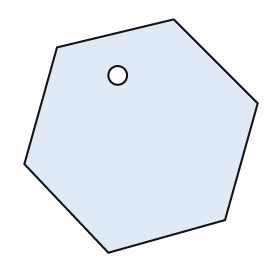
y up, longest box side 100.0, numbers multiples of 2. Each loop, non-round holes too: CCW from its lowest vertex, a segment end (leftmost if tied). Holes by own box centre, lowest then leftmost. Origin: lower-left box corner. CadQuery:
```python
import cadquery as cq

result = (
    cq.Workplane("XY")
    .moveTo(36.0, 0.0)
    .lineTo(86.0, 14.0)
    .lineTo(100.0, 64.0)
    .lineTo(64.0, 100.0)
    .lineTo(14.0, 88.0)
    .lineTo(0.0, 38.0)
    .close()
    .moveTo(40.0, 76.0)
    .circle(4.0)
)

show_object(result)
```